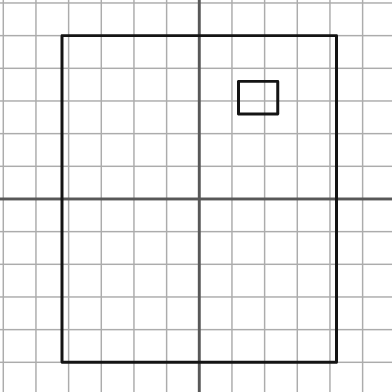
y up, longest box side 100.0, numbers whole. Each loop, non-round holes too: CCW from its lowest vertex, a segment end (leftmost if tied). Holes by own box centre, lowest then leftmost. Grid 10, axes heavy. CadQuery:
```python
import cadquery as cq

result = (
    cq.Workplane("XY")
    .moveTo(-42.0, -50.0)
    .lineTo(42.0, -50.0)
    .lineTo(42.0, 50.0)
    .lineTo(-42.0, 50.0)
    .close()
    .moveTo(12.0, 26.0)
    .lineTo(24.0, 26.0)
    .lineTo(24.0, 36.0)
    .lineTo(12.0, 36.0)
    .close()
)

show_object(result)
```